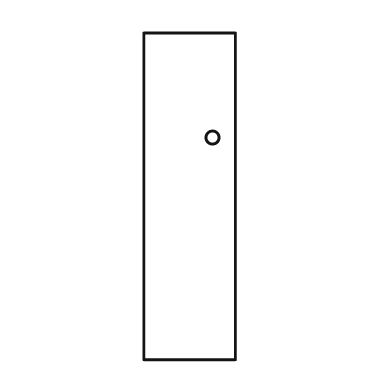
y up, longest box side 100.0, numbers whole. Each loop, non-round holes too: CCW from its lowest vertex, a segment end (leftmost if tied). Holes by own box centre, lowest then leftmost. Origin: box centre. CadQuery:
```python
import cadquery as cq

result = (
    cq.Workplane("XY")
    .moveTo(-14.0, -50.0)
    .lineTo(14.0, -50.0)
    .lineTo(14.0, 50.0)
    .lineTo(-14.0, 50.0)
    .close()
    .moveTo(7.0, 18.0)
    .circle(2.0)
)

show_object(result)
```